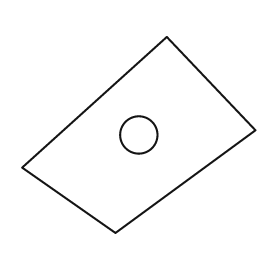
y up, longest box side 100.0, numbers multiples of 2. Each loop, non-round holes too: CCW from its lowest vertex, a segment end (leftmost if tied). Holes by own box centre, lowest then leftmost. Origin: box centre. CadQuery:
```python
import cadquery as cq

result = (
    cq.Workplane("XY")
    .moveTo(-10.0, -42.0)
    .lineTo(50.0, 2.0)
    .lineTo(12.0, 42.0)
    .lineTo(-50.0, -14.0)
    .close()
    .moveTo(0.0, 0.0)
    .circle(8.0)
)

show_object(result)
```